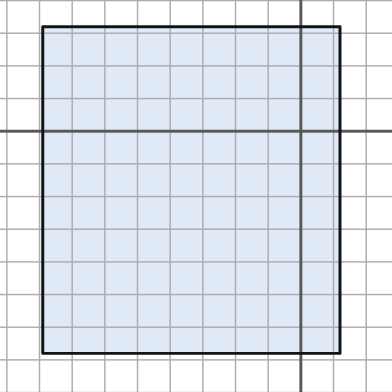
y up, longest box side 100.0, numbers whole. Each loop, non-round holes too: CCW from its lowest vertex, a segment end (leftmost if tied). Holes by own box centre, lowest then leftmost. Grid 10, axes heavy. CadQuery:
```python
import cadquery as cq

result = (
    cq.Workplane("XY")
    .moveTo(-79.0, -68.0)
    .lineTo(12.0, -68.0)
    .lineTo(12.0, 32.0)
    .lineTo(-79.0, 32.0)
    .close()
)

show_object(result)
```